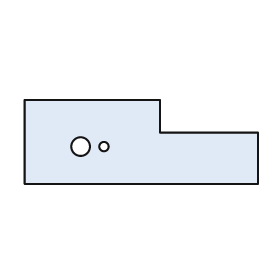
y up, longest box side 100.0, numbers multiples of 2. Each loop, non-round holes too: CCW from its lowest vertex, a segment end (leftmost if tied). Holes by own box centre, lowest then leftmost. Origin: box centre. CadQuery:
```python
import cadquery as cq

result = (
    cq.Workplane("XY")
    .moveTo(-50.0, -18.0)
    .lineTo(50.0, -18.0)
    .lineTo(50.0, 4.0)
    .lineTo(8.0, 4.0)
    .lineTo(8.0, 18.0)
    .lineTo(-50.0, 18.0)
    .close()
    .moveTo(-26.0, -2.0)
    .circle(4.0)
    .moveTo(-16.0, -2.0)
    .circle(2.0)
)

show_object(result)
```